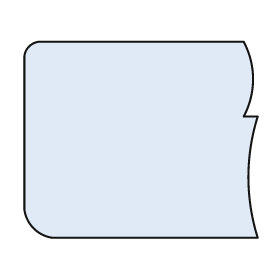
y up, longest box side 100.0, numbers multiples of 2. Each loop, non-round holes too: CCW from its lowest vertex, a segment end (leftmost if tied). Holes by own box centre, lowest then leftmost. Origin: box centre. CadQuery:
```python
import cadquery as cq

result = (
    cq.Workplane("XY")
    .moveTo(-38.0, -42.0)
    .lineTo(50.0, -42.0)
    .threePointArc((46.0, -16.0), (50.0, 10.0))
    .lineTo(44.0, 10.0)
    .threePointArc((48.0, 26.0), (44.0, 42.0))
    .lineTo(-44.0, 42.0)
    .threePointArc((-48.0, 40.0), (-50.0, 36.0))
    .lineTo(-50.0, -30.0)
    .threePointArc((-46.0, -38.0), (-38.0, -42.0))
    .close()
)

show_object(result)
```